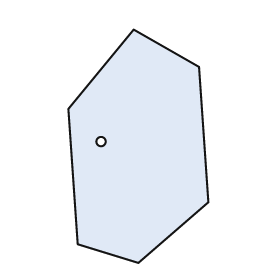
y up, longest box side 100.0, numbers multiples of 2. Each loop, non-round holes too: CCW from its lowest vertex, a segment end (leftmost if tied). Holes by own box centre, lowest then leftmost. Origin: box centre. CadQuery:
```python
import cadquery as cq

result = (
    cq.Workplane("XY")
    .moveTo(0.0, -50.0)
    .lineTo(30.0, -24.0)
    .lineTo(26.0, 34.0)
    .lineTo(-2.0, 50.0)
    .lineTo(-30.0, 16.0)
    .lineTo(-26.0, -42.0)
    .close()
    .moveTo(-16.0, 2.0)
    .circle(2.0)
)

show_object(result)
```